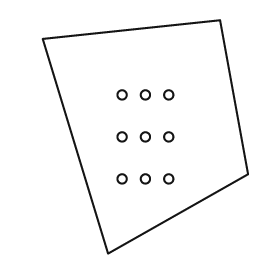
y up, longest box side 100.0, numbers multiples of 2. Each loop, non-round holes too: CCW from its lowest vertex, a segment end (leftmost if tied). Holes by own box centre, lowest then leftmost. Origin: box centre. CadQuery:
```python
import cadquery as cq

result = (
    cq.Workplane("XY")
    .moveTo(-16.0, -50.0)
    .lineTo(44.0, -16.0)
    .lineTo(32.0, 50.0)
    .lineTo(-44.0, 42.0)
    .close()
    .moveTo(-10.0, -18.0)
    .circle(2.0)
    .moveTo(0.0, -18.0)
    .circle(2.0)
    .moveTo(10.0, -18.0)
    .circle(2.0)
    .moveTo(-10.0, 0.0)
    .circle(2.0)
    .moveTo(0.0, 0.0)
    .circle(2.0)
    .moveTo(10.0, 0.0)
    .circle(2.0)
    .moveTo(-10.0, 18.0)
    .circle(2.0)
    .moveTo(0.0, 18.0)
    .circle(2.0)
    .moveTo(10.0, 18.0)
    .circle(2.0)
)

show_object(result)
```